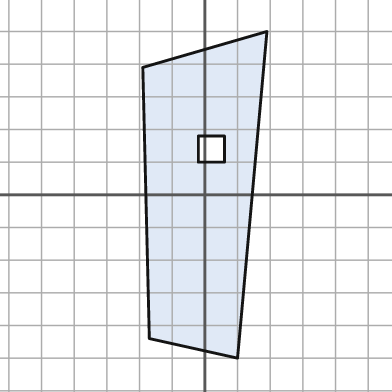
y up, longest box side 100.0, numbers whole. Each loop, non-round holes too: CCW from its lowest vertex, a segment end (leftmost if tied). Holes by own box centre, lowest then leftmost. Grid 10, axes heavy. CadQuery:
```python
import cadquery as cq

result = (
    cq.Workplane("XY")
    .moveTo(10.0, -50.0)
    .lineTo(19.0, 50.0)
    .lineTo(-19.0, 39.0)
    .lineTo(-17.0, -44.0)
    .close()
    .moveTo(-2.0, 10.0)
    .lineTo(6.0, 10.0)
    .lineTo(6.0, 18.0)
    .lineTo(-2.0, 18.0)
    .close()
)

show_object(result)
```